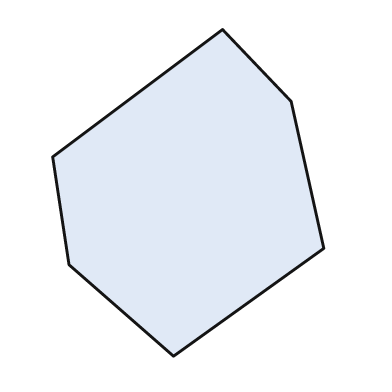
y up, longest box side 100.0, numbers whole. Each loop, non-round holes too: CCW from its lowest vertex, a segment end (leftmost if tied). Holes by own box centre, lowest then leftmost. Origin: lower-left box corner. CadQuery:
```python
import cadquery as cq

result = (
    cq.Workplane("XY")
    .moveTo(37.0, 0.0)
    .lineTo(83.0, 33.0)
    .lineTo(73.0, 78.0)
    .lineTo(52.0, 100.0)
    .lineTo(0.0, 61.0)
    .lineTo(5.0, 28.0)
    .close()
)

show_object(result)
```